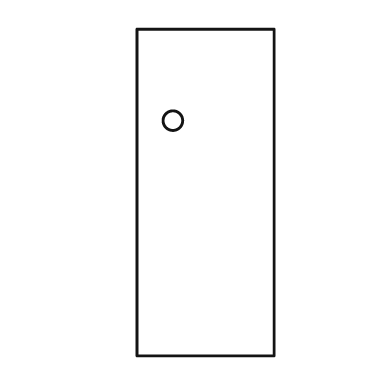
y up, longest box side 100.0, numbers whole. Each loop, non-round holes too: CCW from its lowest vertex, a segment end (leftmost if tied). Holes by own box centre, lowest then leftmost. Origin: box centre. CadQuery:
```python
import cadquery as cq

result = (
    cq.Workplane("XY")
    .moveTo(-21.0, -50.0)
    .lineTo(21.0, -50.0)
    .lineTo(21.0, 50.0)
    .lineTo(-21.0, 50.0)
    .close()
    .moveTo(-10.0, 22.0)
    .circle(3.0)
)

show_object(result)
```